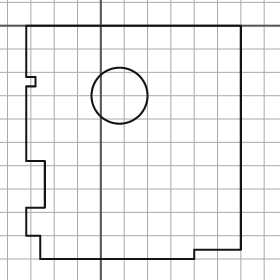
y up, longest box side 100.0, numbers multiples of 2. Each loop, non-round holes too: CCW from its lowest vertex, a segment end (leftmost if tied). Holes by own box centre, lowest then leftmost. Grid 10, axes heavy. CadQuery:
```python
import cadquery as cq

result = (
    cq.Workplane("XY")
    .moveTo(-26.0, -100.0)
    .lineTo(40.0, -100.0)
    .lineTo(40.0, -96.0)
    .lineTo(60.0, -96.0)
    .lineTo(60.0, 0.0)
    .lineTo(-32.0, 0.0)
    .lineTo(-32.0, -22.0)
    .lineTo(-28.0, -22.0)
    .lineTo(-28.0, -26.0)
    .lineTo(-32.0, -26.0)
    .lineTo(-32.0, -58.0)
    .lineTo(-24.0, -58.0)
    .lineTo(-24.0, -78.0)
    .lineTo(-32.0, -78.0)
    .lineTo(-32.0, -90.0)
    .lineTo(-26.0, -90.0)
    .close()
    .moveTo(8.0, -30.0)
    .circle(12.0)
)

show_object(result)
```